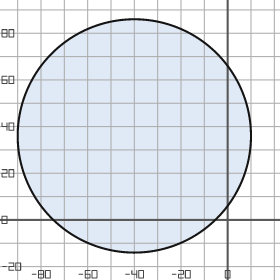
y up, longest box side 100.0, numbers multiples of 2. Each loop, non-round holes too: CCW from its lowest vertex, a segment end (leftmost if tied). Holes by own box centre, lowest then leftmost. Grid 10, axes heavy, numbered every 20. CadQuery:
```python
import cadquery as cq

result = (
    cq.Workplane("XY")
    .moveTo(-40.0, 36.0)
    .circle(50.0)
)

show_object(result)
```